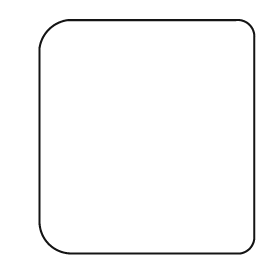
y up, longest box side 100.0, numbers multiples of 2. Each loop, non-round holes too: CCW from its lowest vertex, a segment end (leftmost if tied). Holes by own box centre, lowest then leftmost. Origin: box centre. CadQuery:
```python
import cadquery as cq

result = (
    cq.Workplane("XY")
    .moveTo(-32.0, -50.0)
    .lineTo(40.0, -50.0)
    .threePointArc((44.0, -48.0), (46.0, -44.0))
    .lineTo(46.0, 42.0)
    .threePointArc((44.0, 48.0), (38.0, 50.0))
    .lineTo(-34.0, 50.0)
    .threePointArc((-42.0, 46.0), (-46.0, 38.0))
    .lineTo(-46.0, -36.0)
    .threePointArc((-42.0, -46.0), (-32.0, -50.0))
    .close()
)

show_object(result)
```